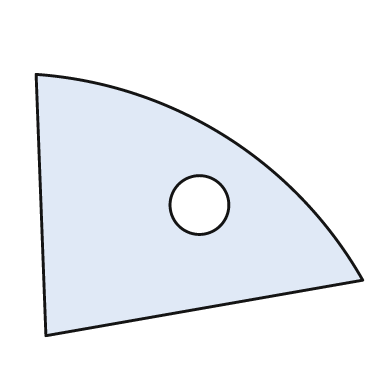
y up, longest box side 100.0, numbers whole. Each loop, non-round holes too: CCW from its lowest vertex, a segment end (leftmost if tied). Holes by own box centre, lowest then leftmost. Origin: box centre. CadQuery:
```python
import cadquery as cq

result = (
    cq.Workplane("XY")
    .moveTo(-47.0, -40.0)
    .lineTo(50.0, -23.0)
    .threePointArc((8.0, 21.0), (-50.0, 40.0))
    .close()
    .moveTo(0.0, 0.0)
    .circle(9.0)
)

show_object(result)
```